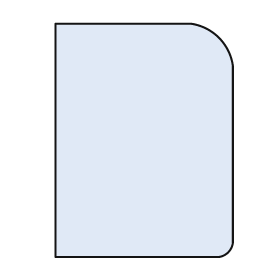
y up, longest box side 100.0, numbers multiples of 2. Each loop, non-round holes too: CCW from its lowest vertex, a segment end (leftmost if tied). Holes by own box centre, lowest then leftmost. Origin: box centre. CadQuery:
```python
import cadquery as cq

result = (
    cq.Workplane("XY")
    .moveTo(-38.0, -50.0)
    .lineTo(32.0, -50.0)
    .threePointArc((36.0, -48.0), (38.0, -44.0))
    .lineTo(38.0, 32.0)
    .threePointArc((32.0, 44.0), (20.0, 50.0))
    .lineTo(-38.0, 50.0)
    .close()
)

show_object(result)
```